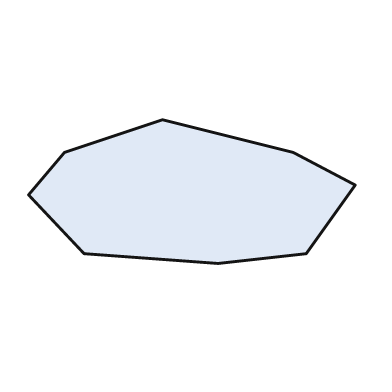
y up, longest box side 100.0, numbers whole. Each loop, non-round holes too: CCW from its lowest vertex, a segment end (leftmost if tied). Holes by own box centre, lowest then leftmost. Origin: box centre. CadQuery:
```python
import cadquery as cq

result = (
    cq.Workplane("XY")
    .moveTo(8.0, -22.0)
    .lineTo(35.0, -19.0)
    .lineTo(50.0, 2.0)
    .lineTo(31.0, 12.0)
    .lineTo(-9.0, 22.0)
    .lineTo(-39.0, 12.0)
    .lineTo(-50.0, -1.0)
    .lineTo(-33.0, -19.0)
    .close()
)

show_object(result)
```